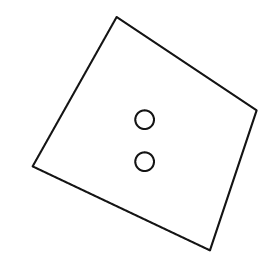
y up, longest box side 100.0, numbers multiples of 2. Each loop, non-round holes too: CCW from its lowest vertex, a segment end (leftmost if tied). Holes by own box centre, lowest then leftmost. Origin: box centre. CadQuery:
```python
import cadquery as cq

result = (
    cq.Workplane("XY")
    .moveTo(28.0, -50.0)
    .lineTo(48.0, 10.0)
    .lineTo(-12.0, 50.0)
    .lineTo(-48.0, -14.0)
    .close()
    .moveTo(0.0, -12.0)
    .circle(4.0)
    .moveTo(0.0, 6.0)
    .circle(4.0)
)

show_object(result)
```